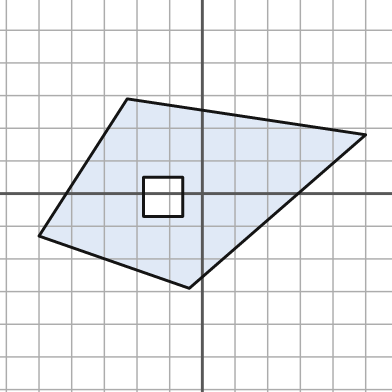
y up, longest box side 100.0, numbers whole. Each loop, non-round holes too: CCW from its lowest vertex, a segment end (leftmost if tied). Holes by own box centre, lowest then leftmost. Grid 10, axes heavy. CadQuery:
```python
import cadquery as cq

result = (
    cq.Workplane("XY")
    .moveTo(-4.0, -29.0)
    .lineTo(50.0, 18.0)
    .lineTo(-23.0, 29.0)
    .lineTo(-50.0, -13.0)
    .close()
    .moveTo(-18.0, -7.0)
    .lineTo(-6.0, -7.0)
    .lineTo(-6.0, 5.0)
    .lineTo(-18.0, 5.0)
    .close()
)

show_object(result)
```